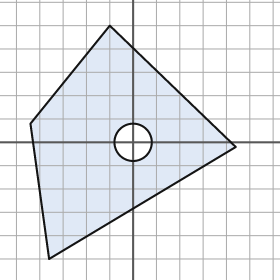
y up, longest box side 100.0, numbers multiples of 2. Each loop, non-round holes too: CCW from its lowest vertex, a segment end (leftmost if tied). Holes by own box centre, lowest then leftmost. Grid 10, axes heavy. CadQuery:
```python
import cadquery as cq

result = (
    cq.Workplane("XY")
    .moveTo(-36.0, -50.0)
    .lineTo(44.0, -2.0)
    .lineTo(-10.0, 50.0)
    .lineTo(-44.0, 8.0)
    .close()
    .moveTo(0.0, 0.0)
    .circle(8.0)
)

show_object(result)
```